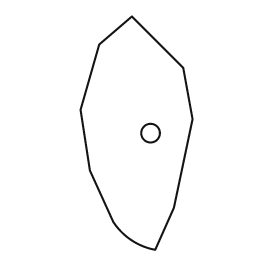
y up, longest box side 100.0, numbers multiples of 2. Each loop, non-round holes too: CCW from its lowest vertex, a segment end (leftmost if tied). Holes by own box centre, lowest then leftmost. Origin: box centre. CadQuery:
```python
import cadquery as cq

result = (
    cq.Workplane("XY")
    .moveTo(8.0, -50.0)
    .lineTo(16.0, -32.0)
    .lineTo(24.0, 6.0)
    .lineTo(20.0, 28.0)
    .lineTo(-2.0, 50.0)
    .lineTo(-16.0, 38.0)
    .lineTo(-24.0, 10.0)
    .lineTo(-20.0, -16.0)
    .lineTo(-10.0, -38.0)
    .threePointArc((-2.0, -46.0), (8.0, -50.0))
    .close()
    .moveTo(6.0, 0.0)
    .circle(4.0)
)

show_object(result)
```